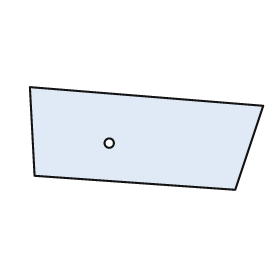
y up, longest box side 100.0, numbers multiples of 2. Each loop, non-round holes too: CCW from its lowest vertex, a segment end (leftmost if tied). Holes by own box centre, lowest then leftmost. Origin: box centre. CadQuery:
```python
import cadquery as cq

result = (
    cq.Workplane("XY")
    .moveTo(38.0, -22.0)
    .lineTo(50.0, 14.0)
    .lineTo(-50.0, 22.0)
    .lineTo(-48.0, -16.0)
    .close()
    .moveTo(-16.0, -2.0)
    .circle(2.0)
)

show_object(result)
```